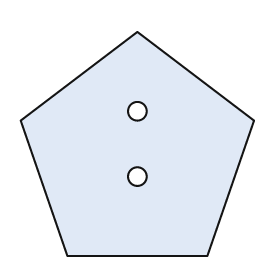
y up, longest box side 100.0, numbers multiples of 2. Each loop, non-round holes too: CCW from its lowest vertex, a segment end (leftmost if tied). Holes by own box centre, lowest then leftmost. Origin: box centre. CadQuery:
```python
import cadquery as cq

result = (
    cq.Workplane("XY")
    .moveTo(-30.0, -48.0)
    .lineTo(30.0, -48.0)
    .lineTo(50.0, 10.0)
    .lineTo(0.0, 48.0)
    .lineTo(-50.0, 10.0)
    .close()
    .moveTo(0.0, -14.0)
    .circle(4.0)
    .moveTo(0.0, 14.0)
    .circle(4.0)
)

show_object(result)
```